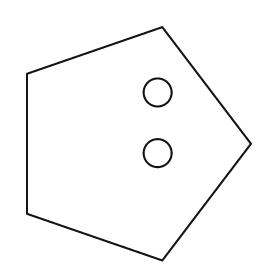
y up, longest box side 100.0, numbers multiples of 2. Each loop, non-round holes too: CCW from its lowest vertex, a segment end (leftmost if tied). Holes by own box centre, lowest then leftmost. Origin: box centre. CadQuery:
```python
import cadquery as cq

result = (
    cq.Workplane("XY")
    .moveTo(10.0, -50.0)
    .lineTo(48.0, 0.0)
    .lineTo(10.0, 50.0)
    .lineTo(-48.0, 30.0)
    .lineTo(-48.0, -30.0)
    .close()
    .moveTo(8.0, -4.0)
    .circle(6.0)
    .moveTo(8.0, 22.0)
    .circle(6.0)
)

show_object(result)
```